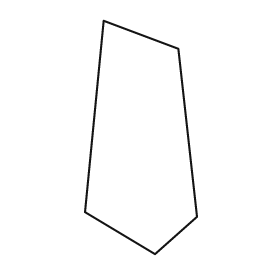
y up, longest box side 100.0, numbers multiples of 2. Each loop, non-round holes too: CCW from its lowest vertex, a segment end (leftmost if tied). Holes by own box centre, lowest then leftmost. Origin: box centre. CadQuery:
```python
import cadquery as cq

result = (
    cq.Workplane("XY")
    .moveTo(6.0, -50.0)
    .lineTo(24.0, -34.0)
    .lineTo(16.0, 38.0)
    .lineTo(-16.0, 50.0)
    .lineTo(-24.0, -32.0)
    .close()
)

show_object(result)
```